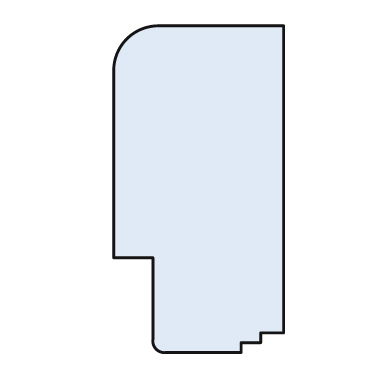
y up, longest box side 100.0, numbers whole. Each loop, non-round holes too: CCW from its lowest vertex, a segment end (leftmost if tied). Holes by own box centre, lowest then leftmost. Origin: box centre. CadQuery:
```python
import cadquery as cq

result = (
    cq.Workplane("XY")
    .moveTo(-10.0, -50.0)
    .lineTo(13.0, -50.0)
    .lineTo(13.0, -47.0)
    .lineTo(19.0, -47.0)
    .lineTo(19.0, -44.0)
    .lineTo(26.0, -44.0)
    .lineTo(26.0, 50.0)
    .lineTo(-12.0, 50.0)
    .threePointArc((-22.0, 46.0), (-26.0, 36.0))
    .lineTo(-26.0, -21.0)
    .lineTo(-14.0, -21.0)
    .lineTo(-14.0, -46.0)
    .threePointArc((-13.0, -49.0), (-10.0, -50.0))
    .close()
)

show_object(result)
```